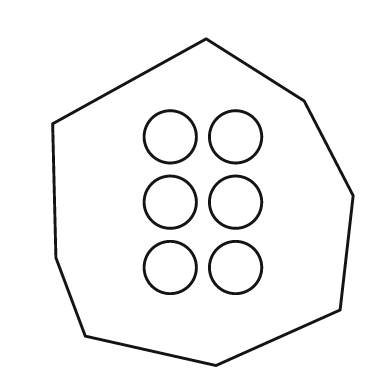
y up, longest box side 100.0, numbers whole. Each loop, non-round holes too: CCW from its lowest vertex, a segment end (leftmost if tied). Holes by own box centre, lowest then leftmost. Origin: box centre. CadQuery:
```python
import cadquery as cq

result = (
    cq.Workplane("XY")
    .moveTo(4.0, -50.0)
    .lineTo(42.0, -33.0)
    .lineTo(46.0, 2.0)
    .lineTo(31.0, 31.0)
    .lineTo(1.0, 50.0)
    .lineTo(-46.0, 24.0)
    .lineTo(-45.0, -17.0)
    .lineTo(-36.0, -41.0)
    .close()
    .moveTo(-10.0, -20.0)
    .circle(8.0)
    .moveTo(10.0, -20.0)
    .circle(8.0)
    .moveTo(-10.0, 0.0)
    .circle(8.0)
    .moveTo(10.0, 0.0)
    .circle(8.0)
    .moveTo(-10.0, 20.0)
    .circle(8.0)
    .moveTo(10.0, 20.0)
    .circle(8.0)
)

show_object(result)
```